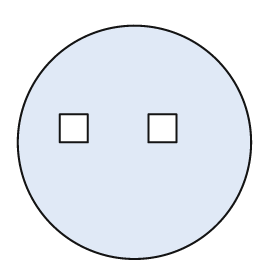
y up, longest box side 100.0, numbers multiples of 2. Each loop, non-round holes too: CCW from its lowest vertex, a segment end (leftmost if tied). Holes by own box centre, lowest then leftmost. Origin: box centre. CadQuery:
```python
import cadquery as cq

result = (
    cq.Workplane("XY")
    .moveTo(0.0, 0.0)
    .circle(50.0)
    .moveTo(-32.0, 0.0)
    .lineTo(-20.0, 0.0)
    .lineTo(-20.0, 12.0)
    .lineTo(-32.0, 12.0)
    .close()
    .moveTo(6.0, 0.0)
    .lineTo(18.0, 0.0)
    .lineTo(18.0, 12.0)
    .lineTo(6.0, 12.0)
    .close()
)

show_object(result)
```